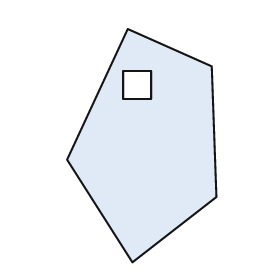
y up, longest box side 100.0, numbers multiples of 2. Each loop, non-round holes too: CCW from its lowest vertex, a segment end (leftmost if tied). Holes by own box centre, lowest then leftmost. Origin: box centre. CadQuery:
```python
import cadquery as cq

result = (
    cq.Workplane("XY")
    .moveTo(-4.0, -50.0)
    .lineTo(32.0, -22.0)
    .lineTo(30.0, 34.0)
    .lineTo(-6.0, 50.0)
    .lineTo(-32.0, -6.0)
    .close()
    .moveTo(-8.0, 20.0)
    .lineTo(4.0, 20.0)
    .lineTo(4.0, 32.0)
    .lineTo(-8.0, 32.0)
    .close()
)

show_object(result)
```